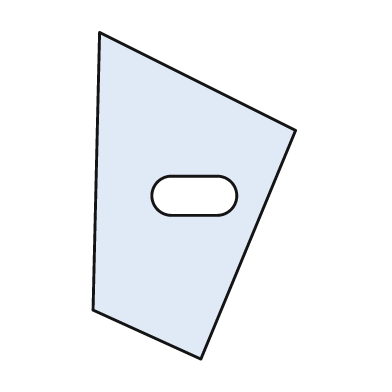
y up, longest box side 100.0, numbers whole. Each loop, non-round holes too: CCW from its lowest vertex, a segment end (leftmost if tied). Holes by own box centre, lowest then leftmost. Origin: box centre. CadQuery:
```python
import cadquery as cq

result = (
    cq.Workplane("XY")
    .moveTo(2.0, -50.0)
    .lineTo(31.0, 20.0)
    .lineTo(-29.0, 50.0)
    .lineTo(-31.0, -35.0)
    .close()
    .moveTo(-7.0, -6.0)
    .lineTo(7.0, -6.0)
    .threePointArc((13.0, 0.0), (7.0, 6.0))
    .lineTo(-7.0, 6.0)
    .threePointArc((-13.0, 0.0), (-7.0, -6.0))
    .close()
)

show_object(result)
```